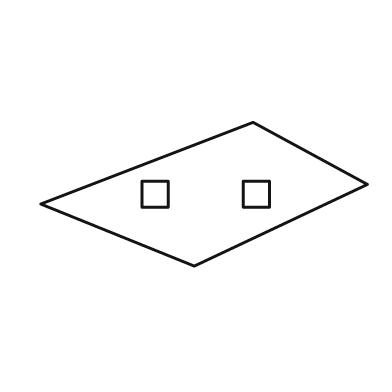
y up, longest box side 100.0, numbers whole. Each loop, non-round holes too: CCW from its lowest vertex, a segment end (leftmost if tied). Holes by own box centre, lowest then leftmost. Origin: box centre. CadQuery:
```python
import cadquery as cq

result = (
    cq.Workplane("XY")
    .moveTo(-3.0, -22.0)
    .lineTo(50.0, 3.0)
    .lineTo(15.0, 22.0)
    .lineTo(-50.0, -3.0)
    .close()
    .moveTo(-19.0, -4.0)
    .lineTo(-11.0, -4.0)
    .lineTo(-11.0, 4.0)
    .lineTo(-19.0, 4.0)
    .close()
    .moveTo(12.0, -4.0)
    .lineTo(20.0, -4.0)
    .lineTo(20.0, 4.0)
    .lineTo(12.0, 4.0)
    .close()
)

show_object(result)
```